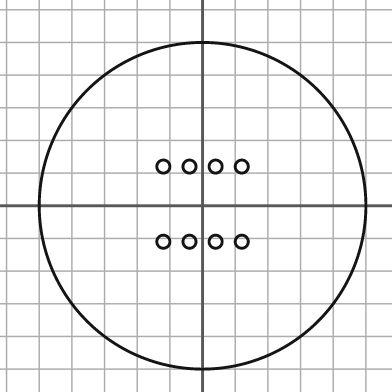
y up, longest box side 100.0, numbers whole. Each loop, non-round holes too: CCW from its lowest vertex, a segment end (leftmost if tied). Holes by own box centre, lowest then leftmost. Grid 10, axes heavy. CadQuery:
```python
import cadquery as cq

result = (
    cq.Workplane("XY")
    .moveTo(0.0, 0.0)
    .circle(50.0)
    .moveTo(-12.0, -11.0)
    .circle(2.0)
    .moveTo(-4.0, -11.0)
    .circle(2.0)
    .moveTo(4.0, -11.0)
    .circle(2.0)
    .moveTo(12.0, -11.0)
    .circle(2.0)
    .moveTo(-12.0, 12.0)
    .circle(2.0)
    .moveTo(-4.0, 12.0)
    .circle(2.0)
    .moveTo(4.0, 12.0)
    .circle(2.0)
    .moveTo(12.0, 12.0)
    .circle(2.0)
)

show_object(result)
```